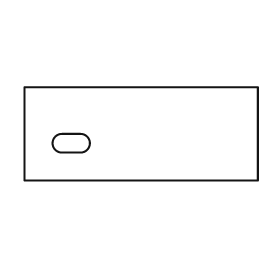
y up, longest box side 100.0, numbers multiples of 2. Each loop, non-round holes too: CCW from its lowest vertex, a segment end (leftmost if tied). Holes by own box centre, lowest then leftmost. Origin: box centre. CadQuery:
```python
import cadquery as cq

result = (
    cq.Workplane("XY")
    .moveTo(-50.0, -20.0)
    .lineTo(50.0, -20.0)
    .lineTo(50.0, 20.0)
    .lineTo(-50.0, 20.0)
    .close()
    .moveTo(-34.0, -8.0)
    .lineTo(-26.0, -8.0)
    .threePointArc((-22.0, -4.0), (-26.0, 0.0))
    .lineTo(-34.0, 0.0)
    .threePointArc((-38.0, -4.0), (-34.0, -8.0))
    .close()
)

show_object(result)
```